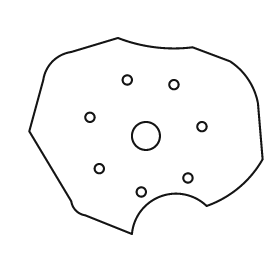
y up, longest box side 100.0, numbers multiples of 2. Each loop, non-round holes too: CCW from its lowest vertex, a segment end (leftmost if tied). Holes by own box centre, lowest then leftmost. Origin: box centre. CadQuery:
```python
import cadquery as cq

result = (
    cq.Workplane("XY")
    .moveTo(-6.0, -42.0)
    .threePointArc((6.0, -26.0), (26.0, -30.0))
    .threePointArc((40.0, -22.0), (50.0, -10.0))
    .lineTo(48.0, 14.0)
    .threePointArc((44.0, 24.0), (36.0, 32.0))
    .lineTo(20.0, 38.0)
    .threePointArc((4.0, 38.0), (-12.0, 42.0))
    .lineTo(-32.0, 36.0)
    .threePointArc((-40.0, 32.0), (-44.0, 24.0))
    .lineTo(-50.0, 2.0)
    .lineTo(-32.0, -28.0)
    .threePointArc((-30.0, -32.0), (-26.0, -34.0))
    .close()
    .moveTo(-2.0, -24.0)
    .circle(2.0)
    .moveTo(18.0, -18.0)
    .circle(2.0)
    .moveTo(-20.0, -14.0)
    .circle(2.0)
    .moveTo(0.0, 0.0)
    .circle(6.0)
    .moveTo(24.0, 4.0)
    .circle(2.0)
    .moveTo(-24.0, 8.0)
    .circle(2.0)
    .moveTo(12.0, 22.0)
    .circle(2.0)
    .moveTo(-8.0, 24.0)
    .circle(2.0)
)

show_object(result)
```